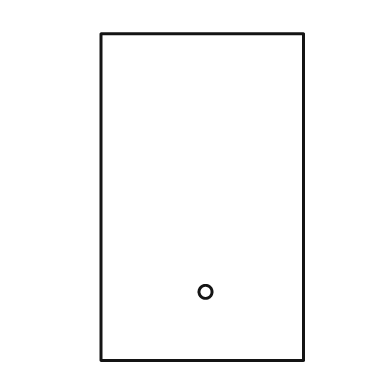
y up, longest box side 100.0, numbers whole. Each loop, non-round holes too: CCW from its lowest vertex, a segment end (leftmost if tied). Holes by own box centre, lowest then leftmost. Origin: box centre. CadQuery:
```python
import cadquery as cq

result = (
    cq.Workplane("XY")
    .moveTo(-31.0, -50.0)
    .lineTo(31.0, -50.0)
    .lineTo(31.0, 50.0)
    .lineTo(-31.0, 50.0)
    .close()
    .moveTo(1.0, -29.0)
    .circle(2.0)
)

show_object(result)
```